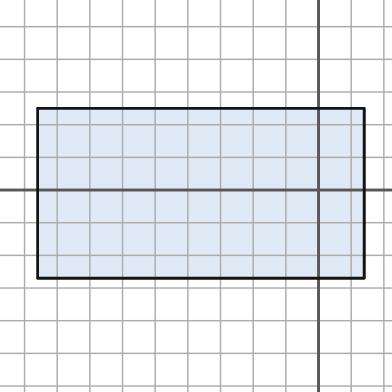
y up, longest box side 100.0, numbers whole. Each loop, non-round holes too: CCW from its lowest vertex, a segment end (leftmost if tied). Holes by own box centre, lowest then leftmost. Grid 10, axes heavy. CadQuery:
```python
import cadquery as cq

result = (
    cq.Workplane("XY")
    .moveTo(-86.0, -27.0)
    .lineTo(14.0, -27.0)
    .lineTo(14.0, 25.0)
    .lineTo(-86.0, 25.0)
    .close()
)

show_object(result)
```